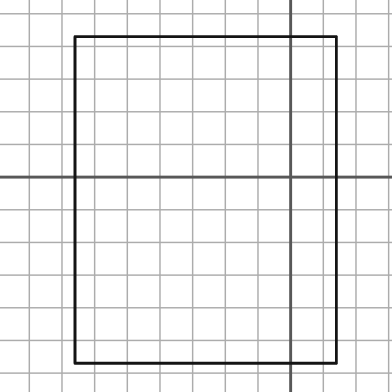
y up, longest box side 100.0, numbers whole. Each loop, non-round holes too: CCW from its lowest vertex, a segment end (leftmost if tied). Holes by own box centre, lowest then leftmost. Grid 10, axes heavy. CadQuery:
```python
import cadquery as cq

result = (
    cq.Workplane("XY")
    .moveTo(-66.0, -57.0)
    .lineTo(14.0, -57.0)
    .lineTo(14.0, 43.0)
    .lineTo(-66.0, 43.0)
    .close()
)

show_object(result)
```